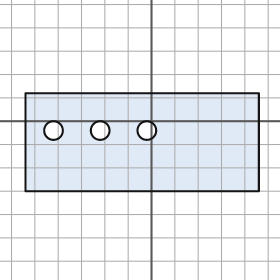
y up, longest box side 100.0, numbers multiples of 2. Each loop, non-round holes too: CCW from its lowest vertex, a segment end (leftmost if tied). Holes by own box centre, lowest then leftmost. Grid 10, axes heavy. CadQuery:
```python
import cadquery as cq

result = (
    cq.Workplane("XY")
    .moveTo(-54.0, -30.0)
    .lineTo(46.0, -30.0)
    .lineTo(46.0, 12.0)
    .lineTo(-54.0, 12.0)
    .close()
    .moveTo(-42.0, -4.0)
    .circle(4.0)
    .moveTo(-22.0, -4.0)
    .circle(4.0)
    .moveTo(-2.0, -4.0)
    .circle(4.0)
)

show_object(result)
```